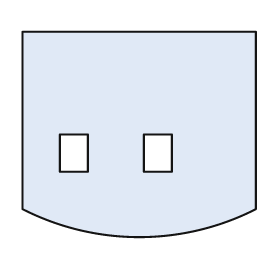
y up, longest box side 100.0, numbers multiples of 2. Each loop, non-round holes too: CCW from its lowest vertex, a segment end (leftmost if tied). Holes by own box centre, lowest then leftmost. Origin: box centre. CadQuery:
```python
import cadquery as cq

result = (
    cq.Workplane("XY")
    .moveTo(-50.0, -32.0)
    .threePointArc((0.0, -44.0), (50.0, -32.0))
    .lineTo(50.0, 44.0)
    .lineTo(-50.0, 44.0)
    .close()
    .moveTo(-34.0, -16.0)
    .lineTo(-22.0, -16.0)
    .lineTo(-22.0, 0.0)
    .lineTo(-34.0, 0.0)
    .close()
    .moveTo(2.0, -16.0)
    .lineTo(14.0, -16.0)
    .lineTo(14.0, 0.0)
    .lineTo(2.0, 0.0)
    .close()
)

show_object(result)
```